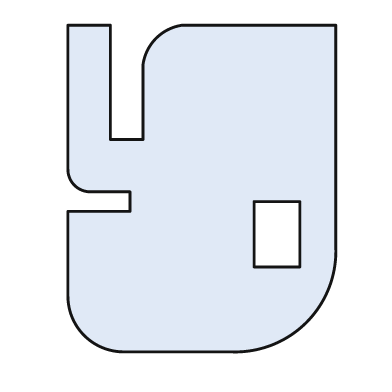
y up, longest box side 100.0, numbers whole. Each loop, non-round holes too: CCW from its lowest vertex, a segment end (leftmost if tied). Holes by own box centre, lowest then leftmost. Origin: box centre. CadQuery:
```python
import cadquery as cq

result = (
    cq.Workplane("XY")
    .moveTo(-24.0, -50.0)
    .lineTo(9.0, -50.0)
    .threePointArc((32.0, -41.0), (41.0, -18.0))
    .lineTo(41.0, 50.0)
    .lineTo(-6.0, 50.0)
    .threePointArc((-14.0, 46.0), (-18.0, 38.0))
    .lineTo(-18.0, 15.0)
    .lineTo(-28.0, 15.0)
    .lineTo(-28.0, 50.0)
    .lineTo(-41.0, 50.0)
    .lineTo(-41.0, 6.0)
    .threePointArc((-39.0, 1.0), (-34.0, -1.0))
    .lineTo(-22.0, -1.0)
    .lineTo(-22.0, -7.0)
    .lineTo(-41.0, -7.0)
    .lineTo(-41.0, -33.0)
    .threePointArc((-36.0, -45.0), (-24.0, -50.0))
    .close()
    .moveTo(16.0, -24.0)
    .lineTo(30.0, -24.0)
    .lineTo(30.0, -4.0)
    .lineTo(16.0, -4.0)
    .close()
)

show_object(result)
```